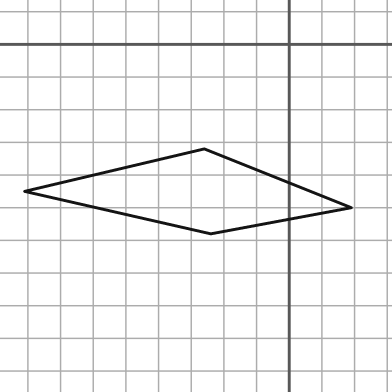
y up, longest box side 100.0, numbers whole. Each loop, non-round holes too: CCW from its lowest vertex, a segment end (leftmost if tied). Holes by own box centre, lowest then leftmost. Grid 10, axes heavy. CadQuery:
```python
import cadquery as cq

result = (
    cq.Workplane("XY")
    .moveTo(-24.0, -58.0)
    .lineTo(19.0, -50.0)
    .lineTo(-26.0, -32.0)
    .lineTo(-81.0, -45.0)
    .close()
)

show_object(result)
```